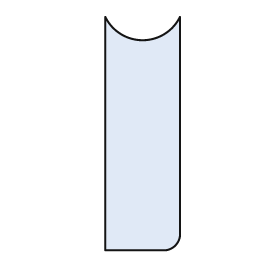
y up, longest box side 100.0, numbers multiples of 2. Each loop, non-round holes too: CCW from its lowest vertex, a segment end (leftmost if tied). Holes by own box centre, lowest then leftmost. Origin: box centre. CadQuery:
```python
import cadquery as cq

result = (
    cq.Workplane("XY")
    .moveTo(-16.0, -50.0)
    .lineTo(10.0, -50.0)
    .threePointArc((14.0, -48.0), (16.0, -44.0))
    .lineTo(16.0, 50.0)
    .threePointArc((0.0, 40.0), (-16.0, 50.0))
    .close()
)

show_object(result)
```